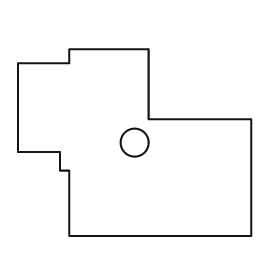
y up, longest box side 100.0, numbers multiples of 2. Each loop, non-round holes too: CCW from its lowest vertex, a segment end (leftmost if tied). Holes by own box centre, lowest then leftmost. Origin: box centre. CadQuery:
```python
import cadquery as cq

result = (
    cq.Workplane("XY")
    .moveTo(-28.0, -40.0)
    .lineTo(50.0, -40.0)
    .lineTo(50.0, 10.0)
    .lineTo(6.0, 10.0)
    .lineTo(6.0, 40.0)
    .lineTo(-28.0, 40.0)
    .lineTo(-28.0, 34.0)
    .lineTo(-50.0, 34.0)
    .lineTo(-50.0, -4.0)
    .lineTo(-32.0, -4.0)
    .lineTo(-32.0, -12.0)
    .lineTo(-28.0, -12.0)
    .close()
    .moveTo(0.0, 0.0)
    .circle(6.0)
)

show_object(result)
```